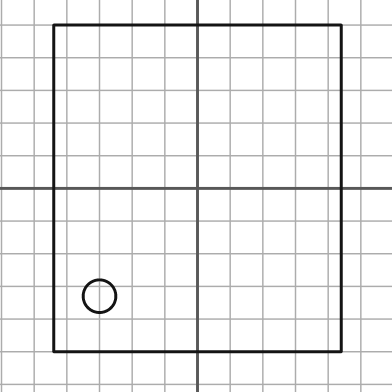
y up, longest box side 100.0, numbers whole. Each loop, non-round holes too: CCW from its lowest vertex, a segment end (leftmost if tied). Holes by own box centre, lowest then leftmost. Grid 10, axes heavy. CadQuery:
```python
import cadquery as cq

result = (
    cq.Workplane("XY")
    .moveTo(-44.0, -50.0)
    .lineTo(44.0, -50.0)
    .lineTo(44.0, 50.0)
    .lineTo(-44.0, 50.0)
    .close()
    .moveTo(-30.0, -33.0)
    .circle(5.0)
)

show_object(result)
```